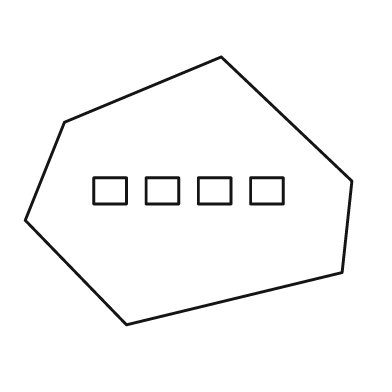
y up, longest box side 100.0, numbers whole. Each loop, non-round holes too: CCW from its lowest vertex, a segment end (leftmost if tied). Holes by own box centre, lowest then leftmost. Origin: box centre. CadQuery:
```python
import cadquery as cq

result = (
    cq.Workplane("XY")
    .moveTo(-19.0, -41.0)
    .lineTo(47.0, -25.0)
    .lineTo(50.0, 3.0)
    .lineTo(10.0, 41.0)
    .lineTo(-38.0, 21.0)
    .lineTo(-50.0, -9.0)
    .close()
    .moveTo(-29.0, -4.0)
    .lineTo(-19.0, -4.0)
    .lineTo(-19.0, 4.0)
    .lineTo(-29.0, 4.0)
    .close()
    .moveTo(-13.0, -4.0)
    .lineTo(-3.0, -4.0)
    .lineTo(-3.0, 4.0)
    .lineTo(-13.0, 4.0)
    .close()
    .moveTo(3.0, -4.0)
    .lineTo(13.0, -4.0)
    .lineTo(13.0, 4.0)
    .lineTo(3.0, 4.0)
    .close()
    .moveTo(19.0, -4.0)
    .lineTo(29.0, -4.0)
    .lineTo(29.0, 4.0)
    .lineTo(19.0, 4.0)
    .close()
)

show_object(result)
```